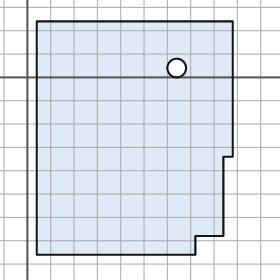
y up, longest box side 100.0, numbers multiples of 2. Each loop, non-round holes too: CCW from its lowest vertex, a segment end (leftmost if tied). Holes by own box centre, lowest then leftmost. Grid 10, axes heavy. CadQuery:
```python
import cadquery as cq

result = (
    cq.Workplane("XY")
    .moveTo(4.0, -76.0)
    .lineTo(72.0, -76.0)
    .lineTo(72.0, -68.0)
    .lineTo(84.0, -68.0)
    .lineTo(84.0, -34.0)
    .lineTo(88.0, -34.0)
    .lineTo(88.0, 24.0)
    .lineTo(4.0, 24.0)
    .close()
    .moveTo(64.0, 4.0)
    .circle(4.0)
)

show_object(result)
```